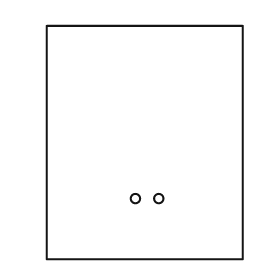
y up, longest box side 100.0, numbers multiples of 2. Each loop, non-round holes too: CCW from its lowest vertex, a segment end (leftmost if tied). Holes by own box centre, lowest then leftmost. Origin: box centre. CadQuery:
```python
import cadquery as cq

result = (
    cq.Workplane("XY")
    .moveTo(-42.0, -50.0)
    .lineTo(42.0, -50.0)
    .lineTo(42.0, 50.0)
    .lineTo(-42.0, 50.0)
    .close()
    .moveTo(-4.0, -24.0)
    .circle(2.0)
    .moveTo(6.0, -24.0)
    .circle(2.0)
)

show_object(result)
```